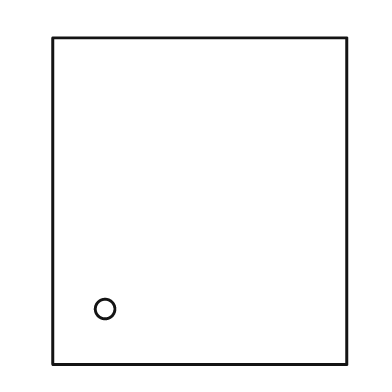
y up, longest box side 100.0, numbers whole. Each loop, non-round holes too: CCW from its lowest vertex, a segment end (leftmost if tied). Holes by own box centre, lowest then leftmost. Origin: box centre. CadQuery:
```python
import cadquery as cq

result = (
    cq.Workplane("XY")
    .moveTo(-45.0, -50.0)
    .lineTo(45.0, -50.0)
    .lineTo(45.0, 50.0)
    .lineTo(-45.0, 50.0)
    .close()
    .moveTo(-29.0, -33.0)
    .circle(3.0)
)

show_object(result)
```